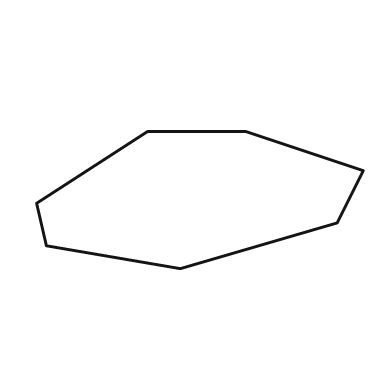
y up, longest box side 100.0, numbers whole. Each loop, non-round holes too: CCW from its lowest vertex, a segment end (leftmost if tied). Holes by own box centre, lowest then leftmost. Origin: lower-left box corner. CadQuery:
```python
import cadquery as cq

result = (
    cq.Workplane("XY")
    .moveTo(44.0, 0.0)
    .lineTo(92.0, 14.0)
    .lineTo(100.0, 30.0)
    .lineTo(64.0, 42.0)
    .lineTo(34.0, 42.0)
    .lineTo(0.0, 20.0)
    .lineTo(3.0, 7.0)
    .close()
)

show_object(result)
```